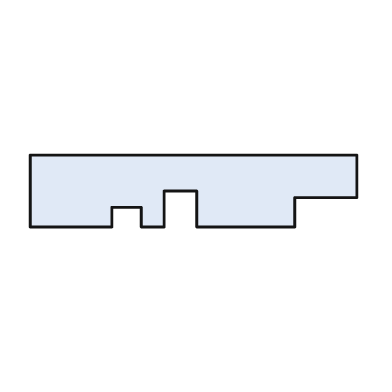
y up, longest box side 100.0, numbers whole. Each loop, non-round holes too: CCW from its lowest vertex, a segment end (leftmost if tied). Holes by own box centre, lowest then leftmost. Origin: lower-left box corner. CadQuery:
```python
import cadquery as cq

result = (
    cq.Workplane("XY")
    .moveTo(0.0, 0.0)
    .lineTo(25.0, 0.0)
    .lineTo(25.0, 6.0)
    .lineTo(34.0, 6.0)
    .lineTo(34.0, 0.0)
    .lineTo(41.0, 0.0)
    .lineTo(41.0, 11.0)
    .lineTo(51.0, 11.0)
    .lineTo(51.0, 0.0)
    .lineTo(81.0, 0.0)
    .lineTo(81.0, 9.0)
    .lineTo(100.0, 9.0)
    .lineTo(100.0, 22.0)
    .lineTo(0.0, 22.0)
    .close()
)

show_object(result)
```